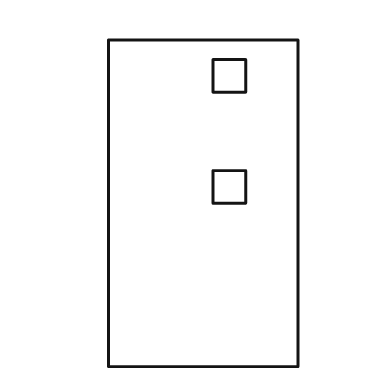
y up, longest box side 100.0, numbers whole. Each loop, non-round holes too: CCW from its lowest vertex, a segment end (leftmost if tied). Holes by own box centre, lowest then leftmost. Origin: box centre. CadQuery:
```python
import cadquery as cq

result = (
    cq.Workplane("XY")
    .moveTo(-29.0, -50.0)
    .lineTo(29.0, -50.0)
    .lineTo(29.0, 50.0)
    .lineTo(-29.0, 50.0)
    .close()
    .moveTo(3.0, 0.0)
    .lineTo(13.0, 0.0)
    .lineTo(13.0, 10.0)
    .lineTo(3.0, 10.0)
    .close()
    .moveTo(3.0, 34.0)
    .lineTo(13.0, 34.0)
    .lineTo(13.0, 44.0)
    .lineTo(3.0, 44.0)
    .close()
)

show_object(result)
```